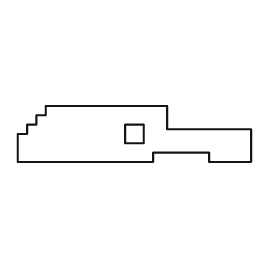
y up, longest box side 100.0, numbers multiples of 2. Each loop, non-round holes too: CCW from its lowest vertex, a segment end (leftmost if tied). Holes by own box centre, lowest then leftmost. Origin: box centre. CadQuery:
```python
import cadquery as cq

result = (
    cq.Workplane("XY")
    .moveTo(-50.0, -12.0)
    .lineTo(8.0, -12.0)
    .lineTo(8.0, -8.0)
    .lineTo(32.0, -8.0)
    .lineTo(32.0, -12.0)
    .lineTo(50.0, -12.0)
    .lineTo(50.0, 2.0)
    .lineTo(14.0, 2.0)
    .lineTo(14.0, 12.0)
    .lineTo(-38.0, 12.0)
    .lineTo(-38.0, 8.0)
    .lineTo(-42.0, 8.0)
    .lineTo(-42.0, 4.0)
    .lineTo(-46.0, 4.0)
    .lineTo(-46.0, 0.0)
    .lineTo(-50.0, 0.0)
    .close()
    .moveTo(-4.0, -4.0)
    .lineTo(4.0, -4.0)
    .lineTo(4.0, 4.0)
    .lineTo(-4.0, 4.0)
    .close()
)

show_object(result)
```